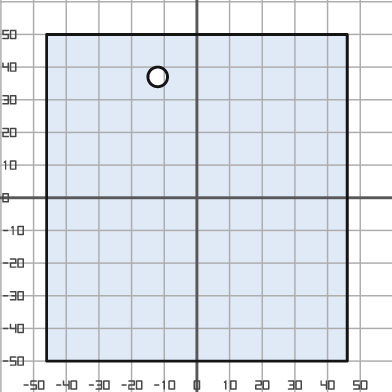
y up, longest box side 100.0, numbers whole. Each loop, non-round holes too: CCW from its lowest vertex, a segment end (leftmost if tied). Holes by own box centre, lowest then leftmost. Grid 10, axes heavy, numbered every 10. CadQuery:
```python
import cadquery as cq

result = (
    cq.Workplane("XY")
    .moveTo(-46.0, -50.0)
    .lineTo(46.0, -50.0)
    .lineTo(46.0, 50.0)
    .lineTo(-46.0, 50.0)
    .close()
    .moveTo(-12.0, 37.0)
    .circle(3.0)
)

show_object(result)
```